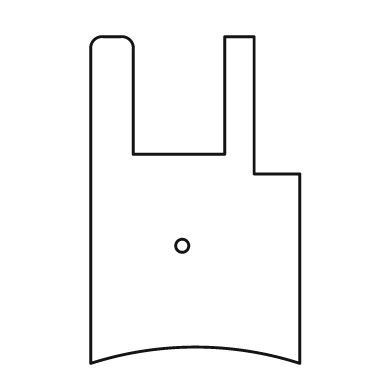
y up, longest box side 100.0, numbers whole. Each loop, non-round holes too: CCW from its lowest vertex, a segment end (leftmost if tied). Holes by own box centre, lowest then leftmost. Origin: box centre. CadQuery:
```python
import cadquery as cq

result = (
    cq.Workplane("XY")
    .moveTo(-32.0, -50.0)
    .threePointArc((0.0, -45.0), (32.0, -50.0))
    .lineTo(32.0, 8.0)
    .lineTo(18.0, 8.0)
    .lineTo(18.0, 50.0)
    .lineTo(9.0, 50.0)
    .lineTo(9.0, 14.0)
    .lineTo(-19.0, 14.0)
    .lineTo(-19.0, 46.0)
    .threePointArc((-20.0, 49.0), (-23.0, 50.0))
    .lineTo(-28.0, 50.0)
    .threePointArc((-31.0, 49.0), (-32.0, 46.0))
    .close()
    .moveTo(-4.0, -14.0)
    .circle(2.0)
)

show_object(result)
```